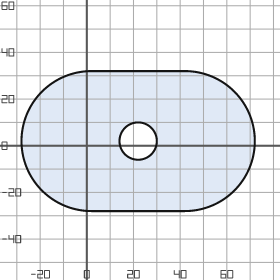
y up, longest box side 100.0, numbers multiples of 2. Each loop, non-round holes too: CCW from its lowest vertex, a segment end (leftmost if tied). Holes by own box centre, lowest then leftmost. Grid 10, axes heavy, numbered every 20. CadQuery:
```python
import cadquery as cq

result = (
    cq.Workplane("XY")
    .moveTo(2.0, -28.0)
    .lineTo(42.0, -28.0)
    .threePointArc((72.0, 2.0), (42.0, 32.0))
    .lineTo(2.0, 32.0)
    .threePointArc((-28.0, 2.0), (2.0, -28.0))
    .close()
    .moveTo(22.0, 2.0)
    .circle(8.0)
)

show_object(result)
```